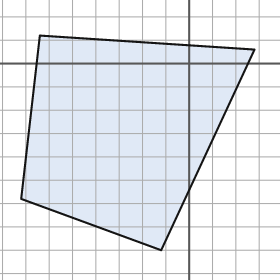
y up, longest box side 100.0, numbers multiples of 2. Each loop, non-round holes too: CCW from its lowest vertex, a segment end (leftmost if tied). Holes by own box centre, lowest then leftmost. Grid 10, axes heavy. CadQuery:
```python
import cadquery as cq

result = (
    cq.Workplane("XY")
    .moveTo(-12.0, -80.0)
    .lineTo(28.0, 6.0)
    .lineTo(-64.0, 12.0)
    .lineTo(-72.0, -58.0)
    .close()
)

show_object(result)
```